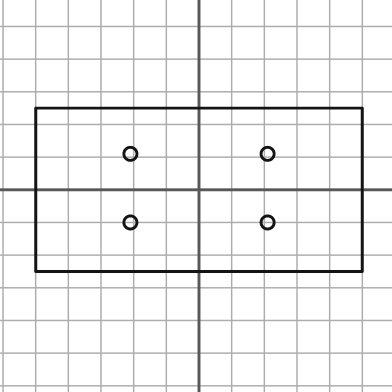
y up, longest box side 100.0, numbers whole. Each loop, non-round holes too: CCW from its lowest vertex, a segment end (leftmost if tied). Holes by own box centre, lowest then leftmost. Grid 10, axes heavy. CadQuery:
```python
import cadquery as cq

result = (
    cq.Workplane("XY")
    .moveTo(-50.0, -25.0)
    .lineTo(50.0, -25.0)
    .lineTo(50.0, 25.0)
    .lineTo(-50.0, 25.0)
    .close()
    .moveTo(-21.0, -10.0)
    .circle(2.0)
    .moveTo(21.0, -10.0)
    .circle(2.0)
    .moveTo(-21.0, 11.0)
    .circle(2.0)
    .moveTo(21.0, 11.0)
    .circle(2.0)
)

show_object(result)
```